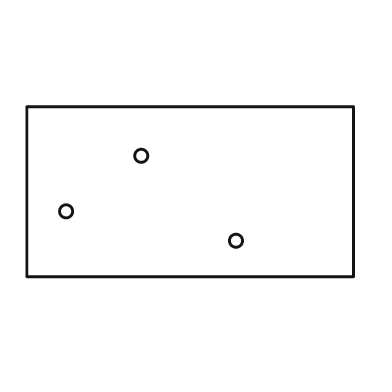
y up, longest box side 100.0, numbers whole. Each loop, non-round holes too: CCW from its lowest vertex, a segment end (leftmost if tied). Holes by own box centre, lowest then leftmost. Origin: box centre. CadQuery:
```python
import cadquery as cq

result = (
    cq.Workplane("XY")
    .moveTo(-50.0, -26.0)
    .lineTo(50.0, -26.0)
    .lineTo(50.0, 26.0)
    .lineTo(-50.0, 26.0)
    .close()
    .moveTo(14.0, -15.0)
    .circle(2.0)
    .moveTo(-38.0, -6.0)
    .circle(2.0)
    .moveTo(-15.0, 11.0)
    .circle(2.0)
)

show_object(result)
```